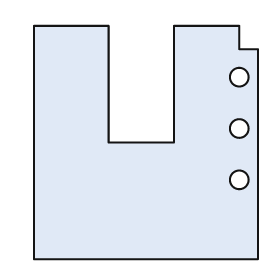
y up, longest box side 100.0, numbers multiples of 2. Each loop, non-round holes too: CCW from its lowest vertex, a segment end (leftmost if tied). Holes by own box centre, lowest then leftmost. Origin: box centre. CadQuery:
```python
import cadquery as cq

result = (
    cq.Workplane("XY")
    .moveTo(-48.0, -50.0)
    .lineTo(48.0, -50.0)
    .lineTo(48.0, 40.0)
    .lineTo(40.0, 40.0)
    .lineTo(40.0, 50.0)
    .lineTo(12.0, 50.0)
    .lineTo(12.0, 0.0)
    .lineTo(-16.0, 0.0)
    .lineTo(-16.0, 50.0)
    .lineTo(-48.0, 50.0)
    .close()
    .moveTo(40.0, -16.0)
    .circle(4.0)
    .moveTo(40.0, 6.0)
    .circle(4.0)
    .moveTo(40.0, 28.0)
    .circle(4.0)
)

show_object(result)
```